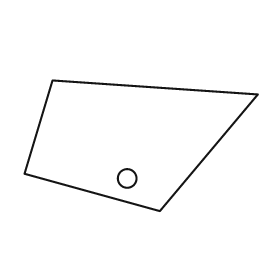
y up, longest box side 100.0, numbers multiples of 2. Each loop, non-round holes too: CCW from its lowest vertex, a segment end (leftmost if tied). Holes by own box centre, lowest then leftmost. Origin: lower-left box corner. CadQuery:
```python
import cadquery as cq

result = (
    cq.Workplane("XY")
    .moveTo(58.0, 0.0)
    .lineTo(100.0, 50.0)
    .lineTo(12.0, 56.0)
    .lineTo(0.0, 16.0)
    .close()
    .moveTo(44.0, 14.0)
    .circle(4.0)
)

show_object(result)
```